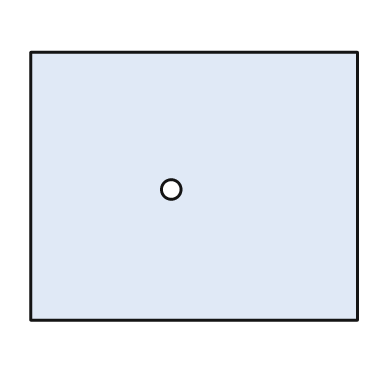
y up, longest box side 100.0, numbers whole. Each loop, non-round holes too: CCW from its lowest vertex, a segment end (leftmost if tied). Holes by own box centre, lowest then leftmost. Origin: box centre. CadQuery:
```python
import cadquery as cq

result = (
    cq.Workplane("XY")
    .moveTo(-50.0, -41.0)
    .lineTo(50.0, -41.0)
    .lineTo(50.0, 41.0)
    .lineTo(-50.0, 41.0)
    .close()
    .moveTo(-7.0, -1.0)
    .circle(3.0)
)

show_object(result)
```